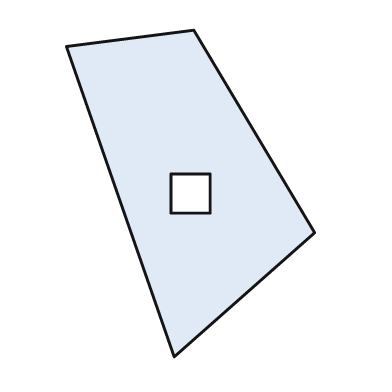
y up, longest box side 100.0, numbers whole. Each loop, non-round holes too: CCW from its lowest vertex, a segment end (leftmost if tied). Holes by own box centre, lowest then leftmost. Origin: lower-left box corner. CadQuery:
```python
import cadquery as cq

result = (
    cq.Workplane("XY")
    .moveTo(33.0, 0.0)
    .lineTo(76.0, 38.0)
    .lineTo(39.0, 100.0)
    .lineTo(0.0, 95.0)
    .close()
    .moveTo(32.0, 44.0)
    .lineTo(44.0, 44.0)
    .lineTo(44.0, 56.0)
    .lineTo(32.0, 56.0)
    .close()
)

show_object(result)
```